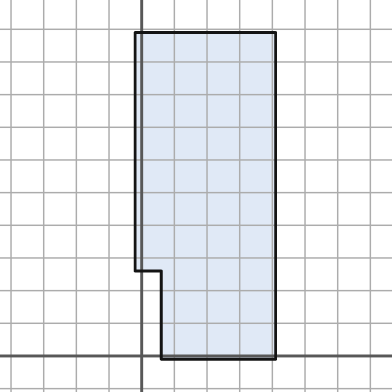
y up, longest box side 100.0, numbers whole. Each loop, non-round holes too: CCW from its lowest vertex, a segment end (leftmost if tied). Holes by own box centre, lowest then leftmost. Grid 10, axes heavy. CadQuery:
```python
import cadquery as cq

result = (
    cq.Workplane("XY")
    .moveTo(6.0, -1.0)
    .lineTo(41.0, -1.0)
    .lineTo(41.0, 99.0)
    .lineTo(-2.0, 99.0)
    .lineTo(-2.0, 26.0)
    .lineTo(6.0, 26.0)
    .close()
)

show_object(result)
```